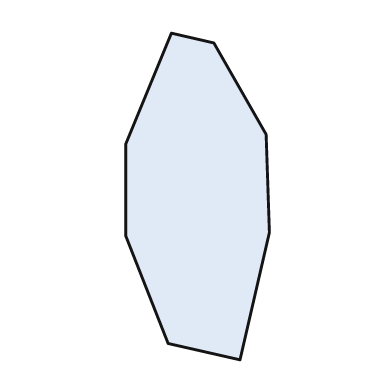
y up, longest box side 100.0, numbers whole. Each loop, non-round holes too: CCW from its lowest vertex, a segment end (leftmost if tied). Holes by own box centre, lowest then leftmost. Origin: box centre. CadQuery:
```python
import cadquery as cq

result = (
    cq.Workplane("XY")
    .moveTo(13.0, -50.0)
    .lineTo(22.0, -11.0)
    .lineTo(21.0, 19.0)
    .lineTo(5.0, 47.0)
    .lineTo(-8.0, 50.0)
    .lineTo(-22.0, 16.0)
    .lineTo(-22.0, -12.0)
    .lineTo(-9.0, -45.0)
    .close()
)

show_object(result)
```